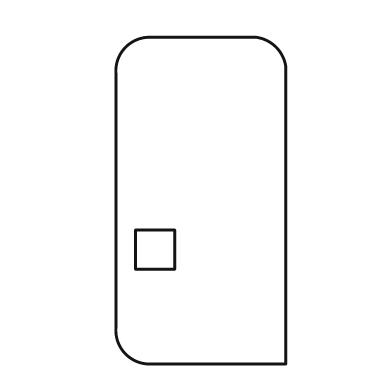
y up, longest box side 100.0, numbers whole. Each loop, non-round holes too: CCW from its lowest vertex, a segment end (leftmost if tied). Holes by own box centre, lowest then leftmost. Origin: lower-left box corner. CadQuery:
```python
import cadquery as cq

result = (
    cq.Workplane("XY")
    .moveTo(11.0, 0.0)
    .lineTo(52.0, 0.0)
    .lineTo(52.0, 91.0)
    .threePointArc((49.0, 97.0), (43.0, 100.0))
    .lineTo(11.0, 100.0)
    .threePointArc((3.0, 97.0), (0.0, 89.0))
    .lineTo(0.0, 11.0)
    .threePointArc((3.0, 3.0), (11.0, 0.0))
    .close()
    .moveTo(6.0, 29.0)
    .lineTo(18.0, 29.0)
    .lineTo(18.0, 41.0)
    .lineTo(6.0, 41.0)
    .close()
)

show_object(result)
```